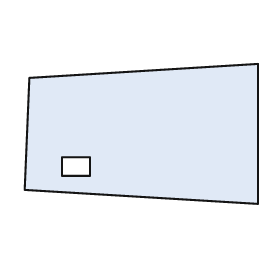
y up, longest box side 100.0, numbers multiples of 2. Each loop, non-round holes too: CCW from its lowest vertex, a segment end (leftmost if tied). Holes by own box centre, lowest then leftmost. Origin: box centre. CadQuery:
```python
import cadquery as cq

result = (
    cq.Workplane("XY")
    .moveTo(50.0, -30.0)
    .lineTo(50.0, 30.0)
    .lineTo(-48.0, 24.0)
    .lineTo(-50.0, -24.0)
    .close()
    .moveTo(-34.0, -18.0)
    .lineTo(-22.0, -18.0)
    .lineTo(-22.0, -10.0)
    .lineTo(-34.0, -10.0)
    .close()
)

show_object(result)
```